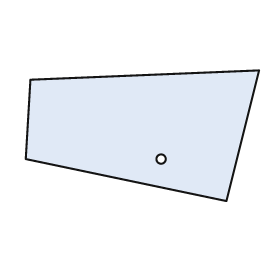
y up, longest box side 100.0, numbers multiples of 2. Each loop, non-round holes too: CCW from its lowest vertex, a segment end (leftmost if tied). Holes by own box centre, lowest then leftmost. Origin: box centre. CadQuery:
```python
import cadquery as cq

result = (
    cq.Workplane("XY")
    .moveTo(36.0, -28.0)
    .lineTo(50.0, 28.0)
    .lineTo(-48.0, 24.0)
    .lineTo(-50.0, -10.0)
    .close()
    .moveTo(8.0, -10.0)
    .circle(2.0)
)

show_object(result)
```